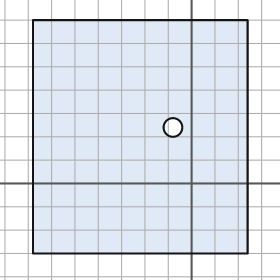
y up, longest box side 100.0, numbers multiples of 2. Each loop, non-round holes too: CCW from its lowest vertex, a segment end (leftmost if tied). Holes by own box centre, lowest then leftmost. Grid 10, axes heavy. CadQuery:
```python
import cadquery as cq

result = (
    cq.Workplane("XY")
    .moveTo(-68.0, -30.0)
    .lineTo(24.0, -30.0)
    .lineTo(24.0, 70.0)
    .lineTo(-68.0, 70.0)
    .close()
    .moveTo(-8.0, 24.0)
    .circle(4.0)
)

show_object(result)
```